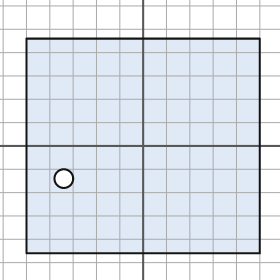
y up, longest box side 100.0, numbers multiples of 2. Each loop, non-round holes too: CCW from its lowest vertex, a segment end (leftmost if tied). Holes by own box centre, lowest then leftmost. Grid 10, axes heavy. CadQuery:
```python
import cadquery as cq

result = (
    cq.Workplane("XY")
    .moveTo(-50.0, -46.0)
    .lineTo(50.0, -46.0)
    .lineTo(50.0, 46.0)
    .lineTo(-50.0, 46.0)
    .close()
    .moveTo(-34.0, -14.0)
    .circle(4.0)
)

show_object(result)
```